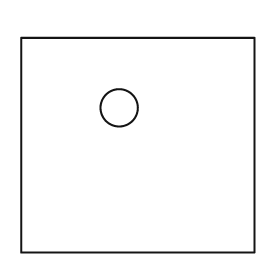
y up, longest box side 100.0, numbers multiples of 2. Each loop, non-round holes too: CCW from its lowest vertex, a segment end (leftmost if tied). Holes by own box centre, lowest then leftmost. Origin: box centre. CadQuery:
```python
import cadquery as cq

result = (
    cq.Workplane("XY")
    .moveTo(-50.0, -46.0)
    .lineTo(50.0, -46.0)
    .lineTo(50.0, 46.0)
    .lineTo(-50.0, 46.0)
    .close()
    .moveTo(-8.0, 16.0)
    .circle(8.0)
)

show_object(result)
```